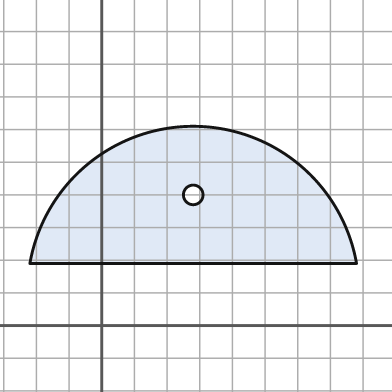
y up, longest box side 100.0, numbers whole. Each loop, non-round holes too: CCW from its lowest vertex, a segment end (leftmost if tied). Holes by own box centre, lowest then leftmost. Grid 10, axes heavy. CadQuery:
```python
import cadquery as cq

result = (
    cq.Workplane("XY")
    .moveTo(-22.0, 19.0)
    .lineTo(78.0, 19.0)
    .threePointArc((28.0, 61.0), (-22.0, 19.0))
    .close()
    .moveTo(28.0, 40.0)
    .circle(3.0)
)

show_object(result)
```